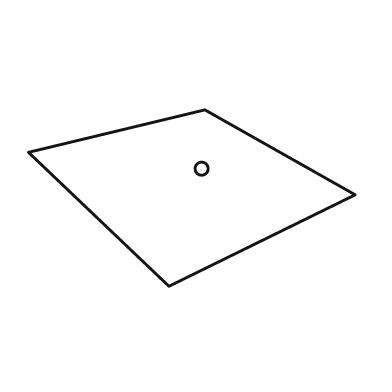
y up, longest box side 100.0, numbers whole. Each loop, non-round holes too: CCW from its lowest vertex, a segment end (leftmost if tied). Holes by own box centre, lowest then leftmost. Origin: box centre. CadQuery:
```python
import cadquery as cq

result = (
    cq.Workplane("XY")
    .moveTo(-7.0, -27.0)
    .lineTo(50.0, 1.0)
    .lineTo(4.0, 27.0)
    .lineTo(-50.0, 14.0)
    .close()
    .moveTo(3.0, 9.0)
    .circle(2.0)
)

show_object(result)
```